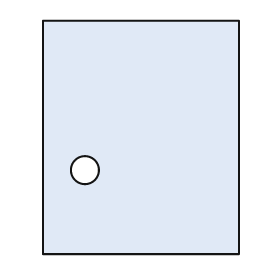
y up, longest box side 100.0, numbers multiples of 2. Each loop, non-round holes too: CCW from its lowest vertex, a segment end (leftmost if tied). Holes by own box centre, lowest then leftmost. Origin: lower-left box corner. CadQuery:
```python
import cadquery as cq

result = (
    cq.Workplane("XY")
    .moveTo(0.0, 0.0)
    .lineTo(84.0, 0.0)
    .lineTo(84.0, 100.0)
    .lineTo(0.0, 100.0)
    .close()
    .moveTo(18.0, 36.0)
    .circle(6.0)
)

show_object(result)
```